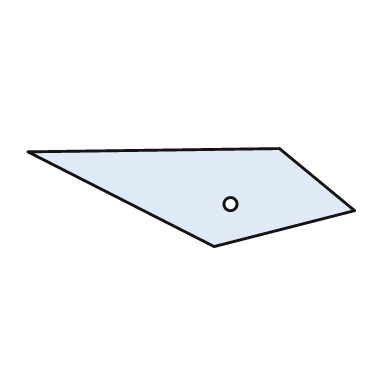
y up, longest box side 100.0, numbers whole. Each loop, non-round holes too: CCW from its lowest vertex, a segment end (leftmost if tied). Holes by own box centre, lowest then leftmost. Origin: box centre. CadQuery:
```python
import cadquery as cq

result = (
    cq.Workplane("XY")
    .moveTo(7.0, -15.0)
    .lineTo(50.0, -4.0)
    .lineTo(27.0, 15.0)
    .lineTo(-50.0, 14.0)
    .close()
    .moveTo(12.0, -2.0)
    .circle(2.0)
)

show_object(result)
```